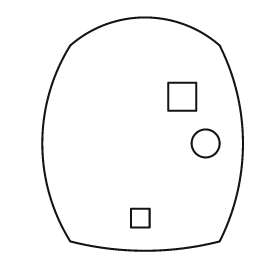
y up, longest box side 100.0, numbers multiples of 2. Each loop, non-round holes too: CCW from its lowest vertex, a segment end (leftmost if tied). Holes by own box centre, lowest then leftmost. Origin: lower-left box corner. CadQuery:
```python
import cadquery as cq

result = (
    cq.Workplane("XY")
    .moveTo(12.0, 4.0)
    .threePointArc((44.0, 0.0), (76.0, 4.0))
    .threePointArc((86.0, 46.0), (76.0, 88.0))
    .threePointArc((44.0, 100.0), (12.0, 88.0))
    .threePointArc((0.0, 46.0), (12.0, 4.0))
    .close()
    .moveTo(38.0, 10.0)
    .lineTo(46.0, 10.0)
    .lineTo(46.0, 18.0)
    .lineTo(38.0, 18.0)
    .close()
    .moveTo(70.0, 46.0)
    .circle(6.0)
    .moveTo(54.0, 60.0)
    .lineTo(66.0, 60.0)
    .lineTo(66.0, 72.0)
    .lineTo(54.0, 72.0)
    .close()
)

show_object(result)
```